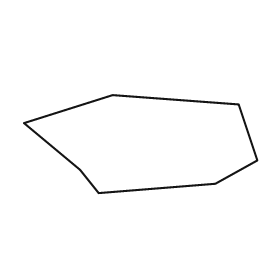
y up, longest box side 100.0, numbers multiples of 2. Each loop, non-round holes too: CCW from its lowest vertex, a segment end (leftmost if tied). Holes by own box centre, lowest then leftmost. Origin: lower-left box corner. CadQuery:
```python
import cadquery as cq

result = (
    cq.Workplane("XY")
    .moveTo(32.0, 0.0)
    .lineTo(82.0, 4.0)
    .lineTo(100.0, 14.0)
    .lineTo(92.0, 38.0)
    .lineTo(38.0, 42.0)
    .lineTo(0.0, 30.0)
    .lineTo(24.0, 10.0)
    .close()
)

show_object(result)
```